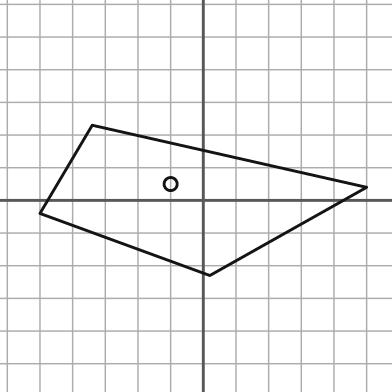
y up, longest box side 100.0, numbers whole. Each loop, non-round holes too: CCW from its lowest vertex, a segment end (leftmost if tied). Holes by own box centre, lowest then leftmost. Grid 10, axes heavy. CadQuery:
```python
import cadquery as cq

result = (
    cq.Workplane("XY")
    .moveTo(2.0, -23.0)
    .lineTo(50.0, 4.0)
    .lineTo(-34.0, 23.0)
    .lineTo(-50.0, -4.0)
    .close()
    .moveTo(-10.0, 5.0)
    .circle(2.0)
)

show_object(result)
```